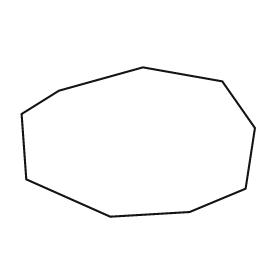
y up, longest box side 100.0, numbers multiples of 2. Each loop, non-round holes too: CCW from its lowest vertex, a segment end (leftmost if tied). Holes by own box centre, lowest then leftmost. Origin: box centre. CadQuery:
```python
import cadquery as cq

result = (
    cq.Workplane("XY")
    .moveTo(-12.0, -32.0)
    .lineTo(22.0, -30.0)
    .lineTo(46.0, -20.0)
    .lineTo(50.0, 6.0)
    .lineTo(36.0, 26.0)
    .lineTo(2.0, 32.0)
    .lineTo(-34.0, 22.0)
    .lineTo(-50.0, 12.0)
    .lineTo(-48.0, -16.0)
    .close()
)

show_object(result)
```